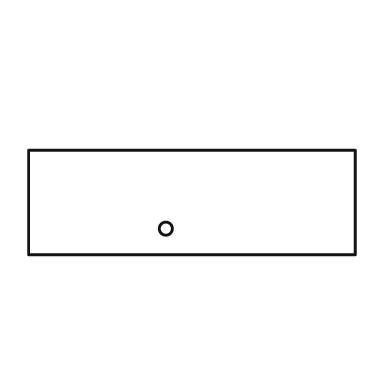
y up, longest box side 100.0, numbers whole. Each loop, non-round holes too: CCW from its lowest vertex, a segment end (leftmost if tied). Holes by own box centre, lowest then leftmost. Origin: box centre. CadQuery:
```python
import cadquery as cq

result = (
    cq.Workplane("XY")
    .moveTo(-50.0, -16.0)
    .lineTo(50.0, -16.0)
    .lineTo(50.0, 16.0)
    .lineTo(-50.0, 16.0)
    .close()
    .moveTo(-8.0, -8.0)
    .circle(2.0)
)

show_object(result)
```